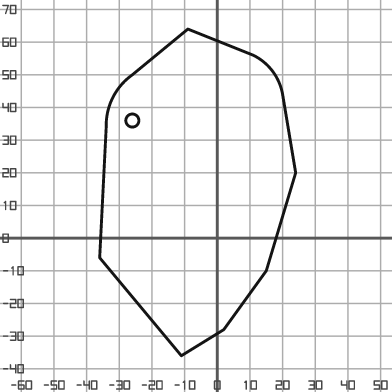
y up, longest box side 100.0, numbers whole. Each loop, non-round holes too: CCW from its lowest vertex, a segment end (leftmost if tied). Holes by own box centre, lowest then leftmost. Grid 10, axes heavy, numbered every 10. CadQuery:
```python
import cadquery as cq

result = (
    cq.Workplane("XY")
    .moveTo(-11.0, -36.0)
    .lineTo(2.0, -28.0)
    .lineTo(15.0, -10.0)
    .lineTo(24.0, 20.0)
    .lineTo(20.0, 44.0)
    .threePointArc((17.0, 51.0), (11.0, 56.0))
    .lineTo(-9.0, 64.0)
    .lineTo(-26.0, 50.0)
    .threePointArc((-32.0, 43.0), (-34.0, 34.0))
    .lineTo(-36.0, -6.0)
    .close()
    .moveTo(-26.0, 36.0)
    .circle(2.0)
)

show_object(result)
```